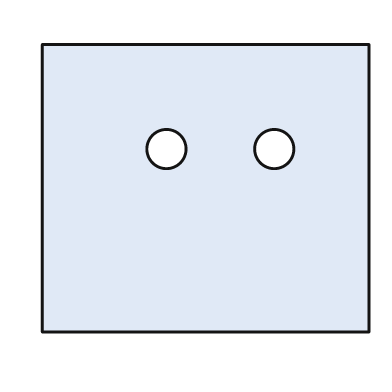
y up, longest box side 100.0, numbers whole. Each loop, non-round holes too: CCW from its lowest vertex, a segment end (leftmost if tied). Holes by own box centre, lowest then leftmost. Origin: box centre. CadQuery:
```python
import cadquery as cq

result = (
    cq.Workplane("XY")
    .moveTo(-50.0, -44.0)
    .lineTo(50.0, -44.0)
    .lineTo(50.0, 44.0)
    .lineTo(-50.0, 44.0)
    .close()
    .moveTo(-12.0, 12.0)
    .circle(6.0)
    .moveTo(21.0, 12.0)
    .circle(6.0)
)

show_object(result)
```